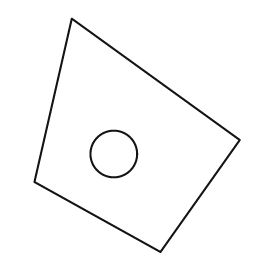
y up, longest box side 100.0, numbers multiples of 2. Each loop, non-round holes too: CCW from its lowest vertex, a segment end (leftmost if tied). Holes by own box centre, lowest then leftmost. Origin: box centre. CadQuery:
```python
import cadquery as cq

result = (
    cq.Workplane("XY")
    .moveTo(10.0, -50.0)
    .lineTo(44.0, -2.0)
    .lineTo(-28.0, 50.0)
    .lineTo(-44.0, -20.0)
    .close()
    .moveTo(-10.0, -8.0)
    .circle(10.0)
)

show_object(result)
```